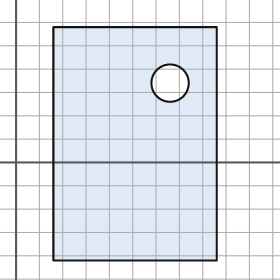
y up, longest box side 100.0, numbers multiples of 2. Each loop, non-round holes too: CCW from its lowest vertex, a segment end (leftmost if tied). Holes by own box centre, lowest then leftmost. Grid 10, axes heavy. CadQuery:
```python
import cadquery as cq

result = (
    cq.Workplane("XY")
    .moveTo(16.0, -42.0)
    .lineTo(86.0, -42.0)
    .lineTo(86.0, 58.0)
    .lineTo(16.0, 58.0)
    .close()
    .moveTo(66.0, 34.0)
    .circle(8.0)
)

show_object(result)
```